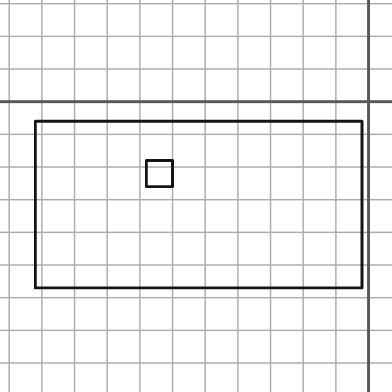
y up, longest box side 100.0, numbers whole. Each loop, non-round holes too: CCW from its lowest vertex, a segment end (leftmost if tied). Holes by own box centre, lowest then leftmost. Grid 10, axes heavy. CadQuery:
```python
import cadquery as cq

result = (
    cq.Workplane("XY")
    .moveTo(-102.0, -57.0)
    .lineTo(-2.0, -57.0)
    .lineTo(-2.0, -6.0)
    .lineTo(-102.0, -6.0)
    .close()
    .moveTo(-68.0, -26.0)
    .lineTo(-60.0, -26.0)
    .lineTo(-60.0, -18.0)
    .lineTo(-68.0, -18.0)
    .close()
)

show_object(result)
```